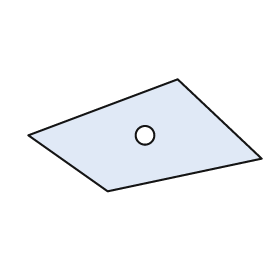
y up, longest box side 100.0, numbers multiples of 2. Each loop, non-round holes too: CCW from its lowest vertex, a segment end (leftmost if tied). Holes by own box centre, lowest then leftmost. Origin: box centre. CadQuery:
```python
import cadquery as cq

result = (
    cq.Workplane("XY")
    .moveTo(-16.0, -24.0)
    .lineTo(50.0, -10.0)
    .lineTo(14.0, 24.0)
    .lineTo(-50.0, 0.0)
    .close()
    .moveTo(0.0, 0.0)
    .circle(4.0)
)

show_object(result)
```